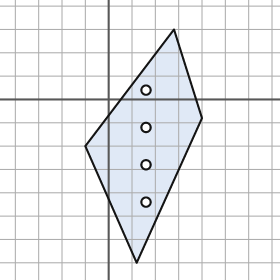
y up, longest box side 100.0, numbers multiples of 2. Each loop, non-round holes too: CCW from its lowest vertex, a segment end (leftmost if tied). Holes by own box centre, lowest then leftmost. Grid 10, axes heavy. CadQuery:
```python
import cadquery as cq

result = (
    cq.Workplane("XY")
    .moveTo(12.0, -70.0)
    .lineTo(40.0, -8.0)
    .lineTo(28.0, 30.0)
    .lineTo(-10.0, -20.0)
    .close()
    .moveTo(16.0, -44.0)
    .circle(2.0)
    .moveTo(16.0, -28.0)
    .circle(2.0)
    .moveTo(16.0, -12.0)
    .circle(2.0)
    .moveTo(16.0, 4.0)
    .circle(2.0)
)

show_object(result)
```